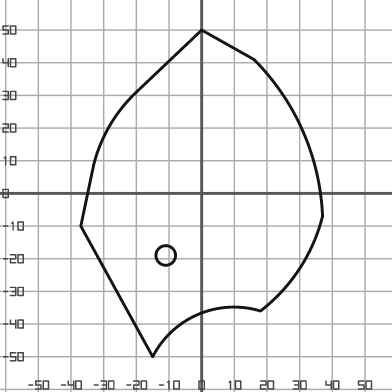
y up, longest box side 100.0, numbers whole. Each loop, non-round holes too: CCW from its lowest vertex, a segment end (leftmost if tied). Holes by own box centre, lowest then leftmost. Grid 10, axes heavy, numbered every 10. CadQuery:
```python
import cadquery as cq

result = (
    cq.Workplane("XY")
    .moveTo(-15.0, -50.0)
    .threePointArc((-1.0, -37.0), (18.0, -36.0))
    .threePointArc((30.0, -23.0), (37.0, -7.0))
    .threePointArc((31.0, 19.0), (16.0, 41.0))
    .lineTo(0.0, 50.0)
    .lineTo(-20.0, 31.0)
    .threePointArc((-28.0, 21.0), (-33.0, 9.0))
    .lineTo(-37.0, -10.0)
    .close()
    .moveTo(-11.0, -19.0)
    .circle(3.0)
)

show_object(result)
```